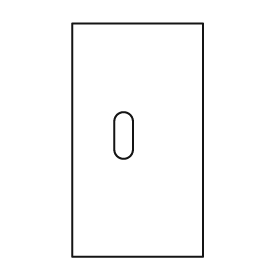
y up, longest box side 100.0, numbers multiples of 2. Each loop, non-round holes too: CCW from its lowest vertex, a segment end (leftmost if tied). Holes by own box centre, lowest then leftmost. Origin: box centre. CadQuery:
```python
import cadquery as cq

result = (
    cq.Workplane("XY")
    .moveTo(-28.0, -50.0)
    .lineTo(28.0, -50.0)
    .lineTo(28.0, 50.0)
    .lineTo(-28.0, 50.0)
    .close()
    .moveTo(-10.0, -4.0)
    .threePointArc((-6.0, -8.0), (-2.0, -4.0))
    .lineTo(-2.0, 8.0)
    .threePointArc((-6.0, 12.0), (-10.0, 8.0))
    .close()
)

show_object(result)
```